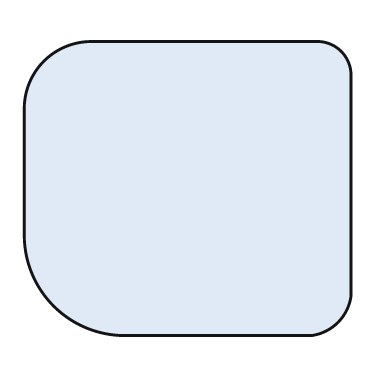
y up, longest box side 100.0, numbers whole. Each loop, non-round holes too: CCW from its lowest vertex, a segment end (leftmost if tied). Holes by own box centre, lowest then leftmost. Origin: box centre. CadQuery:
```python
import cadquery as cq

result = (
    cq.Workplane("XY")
    .moveTo(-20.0, -45.0)
    .lineTo(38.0, -45.0)
    .threePointArc((46.0, -41.0), (50.0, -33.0))
    .lineTo(50.0, 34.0)
    .threePointArc((47.0, 42.0), (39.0, 45.0))
    .lineTo(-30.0, 45.0)
    .threePointArc((-44.0, 39.0), (-50.0, 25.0))
    .lineTo(-50.0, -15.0)
    .threePointArc((-41.0, -36.0), (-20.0, -45.0))
    .close()
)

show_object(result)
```